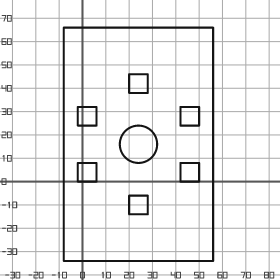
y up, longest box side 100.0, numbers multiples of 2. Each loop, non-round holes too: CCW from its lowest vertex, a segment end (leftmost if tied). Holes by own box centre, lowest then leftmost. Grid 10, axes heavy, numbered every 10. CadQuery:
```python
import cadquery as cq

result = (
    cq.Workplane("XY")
    .moveTo(-8.0, -34.0)
    .lineTo(56.0, -34.0)
    .lineTo(56.0, 66.0)
    .lineTo(-8.0, 66.0)
    .close()
    .moveTo(20.0, -14.0)
    .lineTo(28.0, -14.0)
    .lineTo(28.0, -6.0)
    .lineTo(20.0, -6.0)
    .close()
    .moveTo(-2.0, 0.0)
    .lineTo(6.0, 0.0)
    .lineTo(6.0, 8.0)
    .lineTo(-2.0, 8.0)
    .close()
    .moveTo(42.0, 0.0)
    .lineTo(50.0, 0.0)
    .lineTo(50.0, 8.0)
    .lineTo(42.0, 8.0)
    .close()
    .moveTo(24.0, 16.0)
    .circle(8.0)
    .moveTo(-2.0, 24.0)
    .lineTo(6.0, 24.0)
    .lineTo(6.0, 32.0)
    .lineTo(-2.0, 32.0)
    .close()
    .moveTo(42.0, 24.0)
    .lineTo(50.0, 24.0)
    .lineTo(50.0, 32.0)
    .lineTo(42.0, 32.0)
    .close()
    .moveTo(20.0, 38.0)
    .lineTo(28.0, 38.0)
    .lineTo(28.0, 46.0)
    .lineTo(20.0, 46.0)
    .close()
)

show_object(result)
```